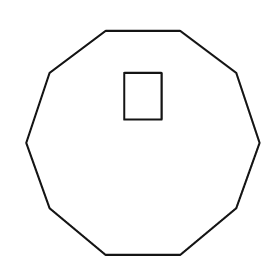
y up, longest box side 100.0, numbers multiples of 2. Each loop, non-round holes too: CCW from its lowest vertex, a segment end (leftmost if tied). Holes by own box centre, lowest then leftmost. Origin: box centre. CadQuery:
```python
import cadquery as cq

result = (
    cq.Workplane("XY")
    .moveTo(-16.0, -48.0)
    .lineTo(16.0, -48.0)
    .lineTo(40.0, -28.0)
    .lineTo(50.0, 0.0)
    .lineTo(40.0, 30.0)
    .lineTo(16.0, 48.0)
    .lineTo(-16.0, 48.0)
    .lineTo(-40.0, 30.0)
    .lineTo(-50.0, 0.0)
    .lineTo(-40.0, -28.0)
    .close()
    .moveTo(-8.0, 10.0)
    .lineTo(8.0, 10.0)
    .lineTo(8.0, 30.0)
    .lineTo(-8.0, 30.0)
    .close()
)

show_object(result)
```